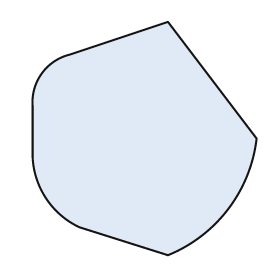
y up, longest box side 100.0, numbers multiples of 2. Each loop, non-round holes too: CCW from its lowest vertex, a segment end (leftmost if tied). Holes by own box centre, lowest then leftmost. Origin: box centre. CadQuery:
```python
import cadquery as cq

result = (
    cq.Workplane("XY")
    .moveTo(10.0, -50.0)
    .threePointArc((36.0, -30.0), (48.0, 0.0))
    .lineTo(10.0, 50.0)
    .lineTo(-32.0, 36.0)
    .threePointArc((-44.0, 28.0), (-48.0, 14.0))
    .lineTo(-48.0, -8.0)
    .threePointArc((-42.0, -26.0), (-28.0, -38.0))
    .close()
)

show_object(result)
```